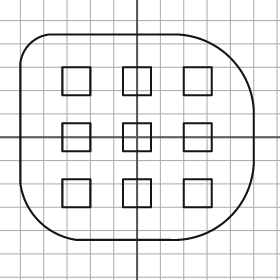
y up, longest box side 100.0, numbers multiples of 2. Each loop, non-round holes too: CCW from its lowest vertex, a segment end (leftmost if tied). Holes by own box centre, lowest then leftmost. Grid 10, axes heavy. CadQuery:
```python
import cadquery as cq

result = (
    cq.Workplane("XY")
    .moveTo(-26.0, -44.0)
    .lineTo(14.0, -44.0)
    .threePointArc((40.0, -34.0), (50.0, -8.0))
    .lineTo(50.0, 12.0)
    .threePointArc((40.0, 34.0), (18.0, 44.0))
    .lineTo(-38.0, 44.0)
    .threePointArc((-46.0, 40.0), (-50.0, 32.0))
    .lineTo(-50.0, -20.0)
    .threePointArc((-42.0, -36.0), (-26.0, -44.0))
    .close()
    .moveTo(-32.0, -30.0)
    .lineTo(-20.0, -30.0)
    .lineTo(-20.0, -18.0)
    .lineTo(-32.0, -18.0)
    .close()
    .moveTo(-6.0, -30.0)
    .lineTo(6.0, -30.0)
    .lineTo(6.0, -18.0)
    .lineTo(-6.0, -18.0)
    .close()
    .moveTo(20.0, -30.0)
    .lineTo(32.0, -30.0)
    .lineTo(32.0, -18.0)
    .lineTo(20.0, -18.0)
    .close()
    .moveTo(-32.0, -6.0)
    .lineTo(-20.0, -6.0)
    .lineTo(-20.0, 6.0)
    .lineTo(-32.0, 6.0)
    .close()
    .moveTo(-6.0, -6.0)
    .lineTo(6.0, -6.0)
    .lineTo(6.0, 6.0)
    .lineTo(-6.0, 6.0)
    .close()
    .moveTo(20.0, -6.0)
    .lineTo(32.0, -6.0)
    .lineTo(32.0, 6.0)
    .lineTo(20.0, 6.0)
    .close()
    .moveTo(-32.0, 18.0)
    .lineTo(-20.0, 18.0)
    .lineTo(-20.0, 30.0)
    .lineTo(-32.0, 30.0)
    .close()
    .moveTo(-6.0, 18.0)
    .lineTo(6.0, 18.0)
    .lineTo(6.0, 30.0)
    .lineTo(-6.0, 30.0)
    .close()
    .moveTo(20.0, 18.0)
    .lineTo(32.0, 18.0)
    .lineTo(32.0, 30.0)
    .lineTo(20.0, 30.0)
    .close()
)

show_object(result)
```